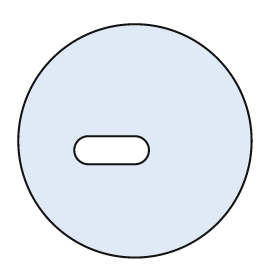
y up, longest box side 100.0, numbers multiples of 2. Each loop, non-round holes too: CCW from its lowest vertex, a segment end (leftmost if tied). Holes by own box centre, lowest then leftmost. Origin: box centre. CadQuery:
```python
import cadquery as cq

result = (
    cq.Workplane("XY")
    .moveTo(0.0, 0.0)
    .circle(50.0)
    .moveTo(-20.0, -10.0)
    .lineTo(0.0, -10.0)
    .threePointArc((6.0, -4.0), (0.0, 2.0))
    .lineTo(-20.0, 2.0)
    .threePointArc((-26.0, -4.0), (-20.0, -10.0))
    .close()
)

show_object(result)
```